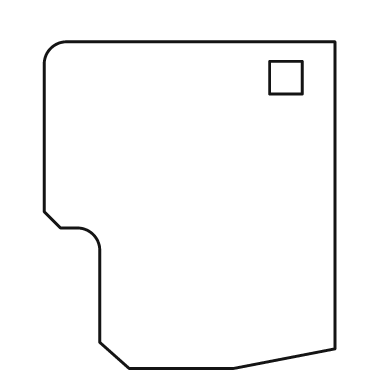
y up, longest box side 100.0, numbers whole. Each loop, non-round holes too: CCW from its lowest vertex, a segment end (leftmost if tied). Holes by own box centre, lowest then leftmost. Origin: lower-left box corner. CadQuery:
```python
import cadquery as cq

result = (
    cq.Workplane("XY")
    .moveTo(26.0, 0.0)
    .lineTo(58.0, 0.0)
    .lineTo(89.0, 6.0)
    .lineTo(89.0, 100.0)
    .lineTo(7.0, 100.0)
    .threePointArc((2.0, 98.0), (0.0, 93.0))
    .lineTo(0.0, 48.0)
    .lineTo(5.0, 43.0)
    .lineTo(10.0, 43.0)
    .threePointArc((15.0, 41.0), (17.0, 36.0))
    .lineTo(17.0, 8.0)
    .close()
    .moveTo(69.0, 84.0)
    .lineTo(79.0, 84.0)
    .lineTo(79.0, 94.0)
    .lineTo(69.0, 94.0)
    .close()
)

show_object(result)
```